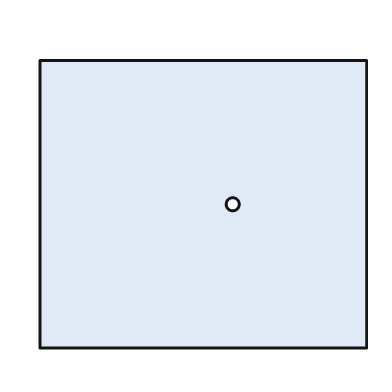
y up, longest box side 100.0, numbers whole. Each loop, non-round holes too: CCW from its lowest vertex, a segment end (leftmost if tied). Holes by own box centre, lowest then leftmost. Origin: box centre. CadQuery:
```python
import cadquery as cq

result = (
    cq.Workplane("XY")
    .moveTo(-50.0, -44.0)
    .lineTo(50.0, -44.0)
    .lineTo(50.0, 44.0)
    .lineTo(-50.0, 44.0)
    .close()
    .moveTo(9.0, 0.0)
    .circle(2.0)
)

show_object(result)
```